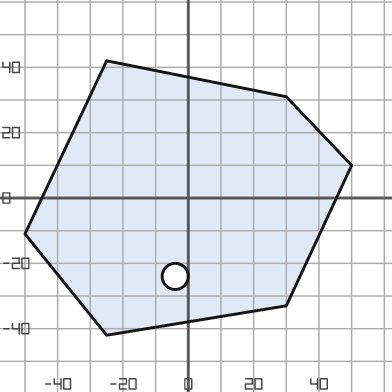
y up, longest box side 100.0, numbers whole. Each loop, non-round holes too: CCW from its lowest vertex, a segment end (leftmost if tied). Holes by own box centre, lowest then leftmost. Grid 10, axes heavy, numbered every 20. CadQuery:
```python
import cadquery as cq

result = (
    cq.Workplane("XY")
    .moveTo(-25.0, -42.0)
    .lineTo(30.0, -33.0)
    .lineTo(50.0, 10.0)
    .lineTo(30.0, 31.0)
    .lineTo(-25.0, 42.0)
    .lineTo(-50.0, -11.0)
    .close()
    .moveTo(-4.0, -24.0)
    .circle(4.0)
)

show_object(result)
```